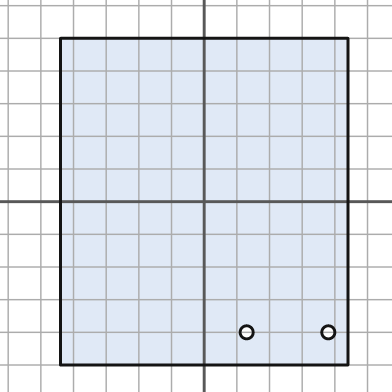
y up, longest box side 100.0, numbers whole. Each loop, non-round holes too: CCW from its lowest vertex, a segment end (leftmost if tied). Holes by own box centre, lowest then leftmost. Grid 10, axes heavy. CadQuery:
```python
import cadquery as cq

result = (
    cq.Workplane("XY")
    .moveTo(-44.0, -50.0)
    .lineTo(44.0, -50.0)
    .lineTo(44.0, 50.0)
    .lineTo(-44.0, 50.0)
    .close()
    .moveTo(13.0, -40.0)
    .circle(2.0)
    .moveTo(38.0, -40.0)
    .circle(2.0)
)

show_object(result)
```